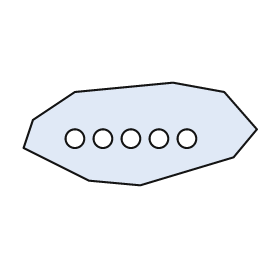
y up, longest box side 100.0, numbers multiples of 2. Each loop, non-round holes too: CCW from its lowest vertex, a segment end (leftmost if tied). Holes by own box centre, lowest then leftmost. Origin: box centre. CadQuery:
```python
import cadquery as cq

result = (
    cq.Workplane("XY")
    .moveTo(0.0, -22.0)
    .lineTo(40.0, -10.0)
    .lineTo(50.0, 2.0)
    .lineTo(36.0, 18.0)
    .lineTo(14.0, 22.0)
    .lineTo(-28.0, 18.0)
    .lineTo(-46.0, 6.0)
    .lineTo(-50.0, -6.0)
    .lineTo(-22.0, -20.0)
    .close()
    .moveTo(-28.0, -2.0)
    .circle(4.0)
    .moveTo(-16.0, -2.0)
    .circle(4.0)
    .moveTo(-4.0, -2.0)
    .circle(4.0)
    .moveTo(8.0, -2.0)
    .circle(4.0)
    .moveTo(20.0, -2.0)
    .circle(4.0)
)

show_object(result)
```